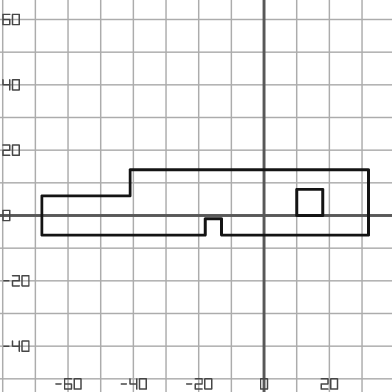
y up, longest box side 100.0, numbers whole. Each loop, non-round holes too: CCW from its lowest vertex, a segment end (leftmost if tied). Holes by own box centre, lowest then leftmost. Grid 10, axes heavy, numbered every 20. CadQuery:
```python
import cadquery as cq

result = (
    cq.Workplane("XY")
    .moveTo(-68.0, -6.0)
    .lineTo(-18.0, -6.0)
    .lineTo(-18.0, -1.0)
    .lineTo(-13.0, -1.0)
    .lineTo(-13.0, -6.0)
    .lineTo(32.0, -6.0)
    .lineTo(32.0, 14.0)
    .lineTo(-41.0, 14.0)
    .lineTo(-41.0, 6.0)
    .lineTo(-68.0, 6.0)
    .close()
    .moveTo(10.0, 0.0)
    .lineTo(18.0, 0.0)
    .lineTo(18.0, 8.0)
    .lineTo(10.0, 8.0)
    .close()
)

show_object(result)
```